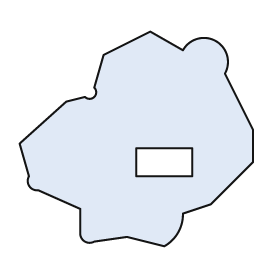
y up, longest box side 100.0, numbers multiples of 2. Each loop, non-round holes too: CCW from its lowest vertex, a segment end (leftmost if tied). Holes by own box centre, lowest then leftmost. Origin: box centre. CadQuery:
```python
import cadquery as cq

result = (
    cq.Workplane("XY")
    .moveTo(12.0, -46.0)
    .threePointArc((18.0, -40.0), (20.0, -32.0))
    .lineTo(32.0, -28.0)
    .lineTo(50.0, -10.0)
    .lineTo(50.0, 4.0)
    .lineTo(38.0, 28.0)
    .threePointArc((34.0, 42.0), (20.0, 38.0))
    .lineTo(6.0, 46.0)
    .lineTo(-14.0, 36.0)
    .lineTo(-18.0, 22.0)
    .threePointArc((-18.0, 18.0), (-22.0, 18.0))
    .lineTo(-30.0, 16.0)
    .lineTo(-50.0, -2.0)
    .lineTo(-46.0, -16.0)
    .threePointArc((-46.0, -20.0), (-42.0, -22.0))
    .lineTo(-24.0, -30.0)
    .lineTo(-24.0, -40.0)
    .threePointArc((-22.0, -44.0), (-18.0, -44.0))
    .lineTo(-4.0, -42.0)
    .close()
    .moveTo(0.0, -16.0)
    .lineTo(24.0, -16.0)
    .lineTo(24.0, -4.0)
    .lineTo(0.0, -4.0)
    .close()
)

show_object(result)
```